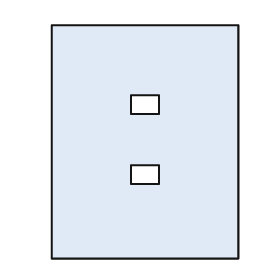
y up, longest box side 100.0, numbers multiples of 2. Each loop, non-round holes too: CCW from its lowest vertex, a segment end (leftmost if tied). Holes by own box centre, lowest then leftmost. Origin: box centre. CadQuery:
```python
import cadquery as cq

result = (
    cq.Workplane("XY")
    .moveTo(-40.0, -50.0)
    .lineTo(40.0, -50.0)
    .lineTo(40.0, 50.0)
    .lineTo(-40.0, 50.0)
    .close()
    .moveTo(-6.0, -18.0)
    .lineTo(6.0, -18.0)
    .lineTo(6.0, -10.0)
    .lineTo(-6.0, -10.0)
    .close()
    .moveTo(-6.0, 12.0)
    .lineTo(6.0, 12.0)
    .lineTo(6.0, 20.0)
    .lineTo(-6.0, 20.0)
    .close()
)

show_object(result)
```